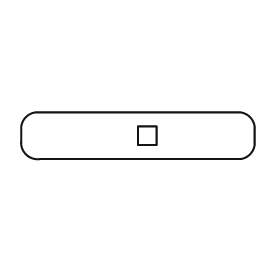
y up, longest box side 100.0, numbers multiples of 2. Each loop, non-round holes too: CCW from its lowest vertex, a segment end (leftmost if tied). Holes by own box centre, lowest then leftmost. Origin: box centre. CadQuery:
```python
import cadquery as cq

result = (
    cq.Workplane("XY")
    .moveTo(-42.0, -10.0)
    .lineTo(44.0, -10.0)
    .threePointArc((48.0, -8.0), (50.0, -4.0))
    .lineTo(50.0, 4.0)
    .threePointArc((48.0, 8.0), (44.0, 10.0))
    .lineTo(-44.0, 10.0)
    .threePointArc((-48.0, 8.0), (-50.0, 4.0))
    .lineTo(-50.0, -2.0)
    .threePointArc((-48.0, -8.0), (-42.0, -10.0))
    .close()
    .moveTo(0.0, -4.0)
    .lineTo(8.0, -4.0)
    .lineTo(8.0, 4.0)
    .lineTo(0.0, 4.0)
    .close()
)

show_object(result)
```